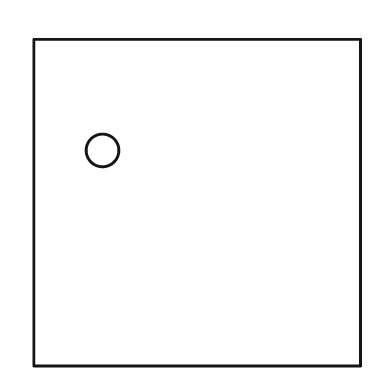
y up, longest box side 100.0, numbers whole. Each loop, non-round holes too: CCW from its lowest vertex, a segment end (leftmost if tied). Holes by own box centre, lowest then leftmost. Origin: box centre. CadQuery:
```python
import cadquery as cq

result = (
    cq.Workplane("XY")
    .moveTo(-50.0, -50.0)
    .lineTo(50.0, -50.0)
    .lineTo(50.0, 50.0)
    .lineTo(-50.0, 50.0)
    .close()
    .moveTo(-29.0, 16.0)
    .circle(5.0)
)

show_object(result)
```